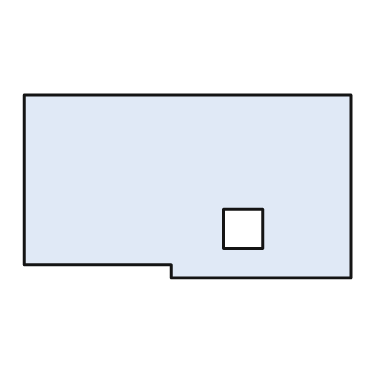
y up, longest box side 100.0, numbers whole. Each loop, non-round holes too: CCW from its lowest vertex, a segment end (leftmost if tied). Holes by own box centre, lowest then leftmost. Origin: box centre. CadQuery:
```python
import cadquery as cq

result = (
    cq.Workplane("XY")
    .moveTo(-5.0, -28.0)
    .lineTo(50.0, -28.0)
    .lineTo(50.0, 28.0)
    .lineTo(-50.0, 28.0)
    .lineTo(-50.0, -24.0)
    .lineTo(-5.0, -24.0)
    .close()
    .moveTo(11.0, -19.0)
    .lineTo(23.0, -19.0)
    .lineTo(23.0, -7.0)
    .lineTo(11.0, -7.0)
    .close()
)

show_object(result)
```